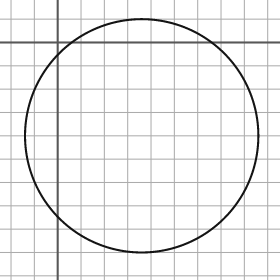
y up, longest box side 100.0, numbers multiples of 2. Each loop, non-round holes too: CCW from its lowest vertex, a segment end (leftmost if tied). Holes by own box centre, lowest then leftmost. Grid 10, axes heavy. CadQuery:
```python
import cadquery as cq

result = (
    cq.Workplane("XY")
    .moveTo(36.0, -40.0)
    .circle(50.0)
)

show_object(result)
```